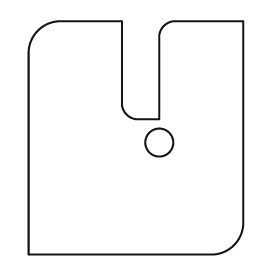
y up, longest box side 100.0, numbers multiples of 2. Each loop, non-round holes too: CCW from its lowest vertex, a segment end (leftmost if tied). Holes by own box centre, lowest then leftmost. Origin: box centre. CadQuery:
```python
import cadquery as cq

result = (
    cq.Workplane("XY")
    .moveTo(-46.0, -50.0)
    .lineTo(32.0, -50.0)
    .threePointArc((42.0, -46.0), (46.0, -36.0))
    .lineTo(46.0, 50.0)
    .lineTo(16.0, 50.0)
    .threePointArc((12.0, 48.0), (10.0, 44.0))
    .lineTo(10.0, 8.0)
    .lineTo(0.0, 8.0)
    .threePointArc((-4.0, 10.0), (-6.0, 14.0))
    .lineTo(-6.0, 50.0)
    .lineTo(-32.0, 50.0)
    .threePointArc((-42.0, 46.0), (-46.0, 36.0))
    .close()
    .moveTo(10.0, -2.0)
    .circle(6.0)
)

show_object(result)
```